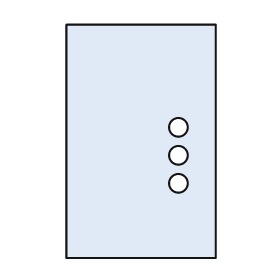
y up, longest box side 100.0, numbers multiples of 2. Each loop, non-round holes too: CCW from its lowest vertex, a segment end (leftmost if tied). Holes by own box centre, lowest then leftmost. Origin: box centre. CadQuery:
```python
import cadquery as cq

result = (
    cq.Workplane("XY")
    .moveTo(-32.0, -50.0)
    .lineTo(32.0, -50.0)
    .lineTo(32.0, 50.0)
    .lineTo(-32.0, 50.0)
    .close()
    .moveTo(16.0, -18.0)
    .circle(4.0)
    .moveTo(16.0, -6.0)
    .circle(4.0)
    .moveTo(16.0, 6.0)
    .circle(4.0)
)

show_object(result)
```